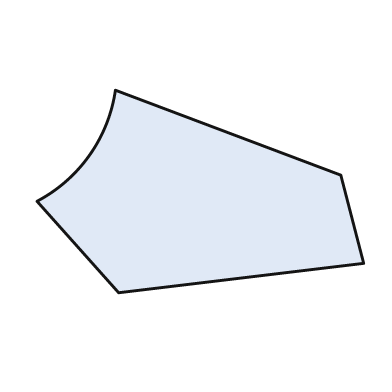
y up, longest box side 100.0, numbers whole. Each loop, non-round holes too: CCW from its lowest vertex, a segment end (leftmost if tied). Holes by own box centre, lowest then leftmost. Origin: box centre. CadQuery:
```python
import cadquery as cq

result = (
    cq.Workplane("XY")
    .moveTo(-25.0, -31.0)
    .lineTo(50.0, -22.0)
    .lineTo(43.0, 5.0)
    .lineTo(-26.0, 31.0)
    .threePointArc((-34.0, 11.0), (-50.0, -3.0))
    .close()
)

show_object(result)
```